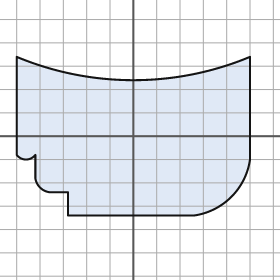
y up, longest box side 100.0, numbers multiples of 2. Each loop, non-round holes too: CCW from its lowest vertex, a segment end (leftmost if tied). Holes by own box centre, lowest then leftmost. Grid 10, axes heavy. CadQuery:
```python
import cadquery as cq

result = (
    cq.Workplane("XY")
    .moveTo(-28.0, -34.0)
    .lineTo(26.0, -34.0)
    .threePointArc((42.0, -26.0), (50.0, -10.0))
    .lineTo(50.0, 34.0)
    .threePointArc((0.0, 24.0), (-50.0, 34.0))
    .lineTo(-50.0, -8.0)
    .threePointArc((-46.0, -10.0), (-42.0, -8.0))
    .lineTo(-42.0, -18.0)
    .threePointArc((-40.0, -22.0), (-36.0, -24.0))
    .lineTo(-28.0, -24.0)
    .close()
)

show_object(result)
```